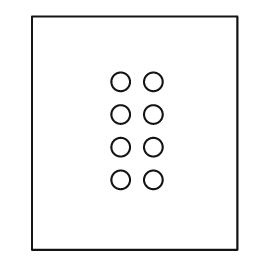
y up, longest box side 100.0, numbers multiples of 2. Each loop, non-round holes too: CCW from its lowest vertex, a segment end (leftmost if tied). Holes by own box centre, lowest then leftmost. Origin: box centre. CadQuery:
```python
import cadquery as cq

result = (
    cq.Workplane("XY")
    .moveTo(-44.0, -50.0)
    .lineTo(44.0, -50.0)
    .lineTo(44.0, 50.0)
    .lineTo(-44.0, 50.0)
    .close()
    .moveTo(-6.0, -20.0)
    .circle(4.0)
    .moveTo(8.0, -20.0)
    .circle(4.0)
    .moveTo(-6.0, -6.0)
    .circle(4.0)
    .moveTo(8.0, -6.0)
    .circle(4.0)
    .moveTo(-6.0, 8.0)
    .circle(4.0)
    .moveTo(8.0, 8.0)
    .circle(4.0)
    .moveTo(-6.0, 22.0)
    .circle(4.0)
    .moveTo(8.0, 22.0)
    .circle(4.0)
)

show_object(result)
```